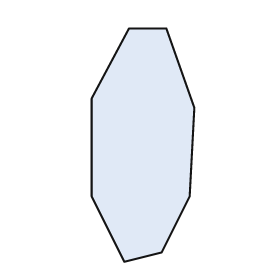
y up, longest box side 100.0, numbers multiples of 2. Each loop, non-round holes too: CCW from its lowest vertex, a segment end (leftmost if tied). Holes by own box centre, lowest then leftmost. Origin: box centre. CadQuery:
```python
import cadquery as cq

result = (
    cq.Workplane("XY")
    .moveTo(-8.0, -50.0)
    .lineTo(8.0, -46.0)
    .lineTo(20.0, -22.0)
    .lineTo(22.0, 16.0)
    .lineTo(10.0, 50.0)
    .lineTo(-6.0, 50.0)
    .lineTo(-22.0, 20.0)
    .lineTo(-22.0, -22.0)
    .close()
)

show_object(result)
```